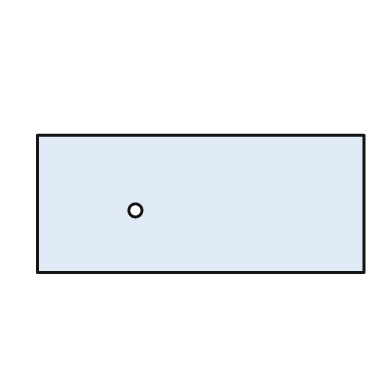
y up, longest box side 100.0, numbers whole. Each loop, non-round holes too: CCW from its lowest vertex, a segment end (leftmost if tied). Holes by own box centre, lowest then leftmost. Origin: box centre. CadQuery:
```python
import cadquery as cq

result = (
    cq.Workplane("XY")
    .moveTo(-50.0, -21.0)
    .lineTo(50.0, -21.0)
    .lineTo(50.0, 21.0)
    .lineTo(-50.0, 21.0)
    .close()
    .moveTo(-20.0, -2.0)
    .circle(2.0)
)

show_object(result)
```